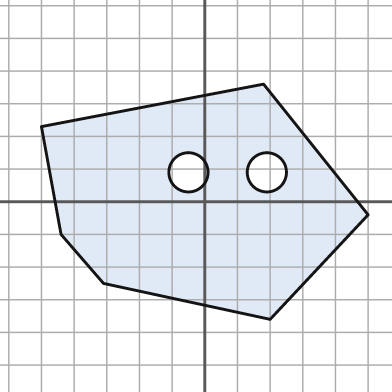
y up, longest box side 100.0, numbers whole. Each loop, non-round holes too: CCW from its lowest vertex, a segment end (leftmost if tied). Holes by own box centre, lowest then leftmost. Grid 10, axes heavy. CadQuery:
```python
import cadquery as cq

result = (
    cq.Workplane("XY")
    .moveTo(20.0, -36.0)
    .lineTo(50.0, -4.0)
    .lineTo(18.0, 36.0)
    .lineTo(-50.0, 23.0)
    .lineTo(-44.0, -10.0)
    .lineTo(-31.0, -25.0)
    .close()
    .moveTo(-5.0, 9.0)
    .circle(6.0)
    .moveTo(19.0, 9.0)
    .circle(6.0)
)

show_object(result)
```